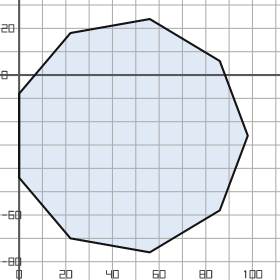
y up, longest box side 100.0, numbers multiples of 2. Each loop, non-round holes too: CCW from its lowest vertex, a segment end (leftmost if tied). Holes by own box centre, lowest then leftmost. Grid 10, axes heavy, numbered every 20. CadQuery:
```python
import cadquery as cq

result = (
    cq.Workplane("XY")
    .moveTo(56.0, -76.0)
    .lineTo(86.0, -58.0)
    .lineTo(98.0, -26.0)
    .lineTo(86.0, 6.0)
    .lineTo(56.0, 24.0)
    .lineTo(22.0, 18.0)
    .lineTo(0.0, -8.0)
    .lineTo(0.0, -44.0)
    .lineTo(22.0, -70.0)
    .close()
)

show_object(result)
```